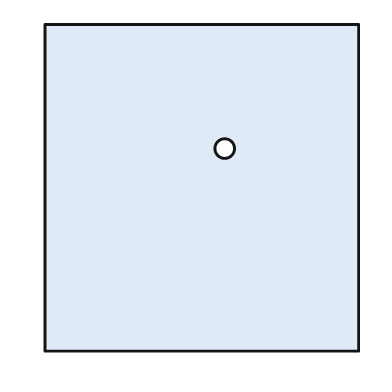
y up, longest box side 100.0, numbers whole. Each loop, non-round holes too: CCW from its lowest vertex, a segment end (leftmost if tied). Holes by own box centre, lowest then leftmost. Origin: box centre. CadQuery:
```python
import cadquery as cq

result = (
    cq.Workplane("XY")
    .moveTo(-48.0, -50.0)
    .lineTo(48.0, -50.0)
    .lineTo(48.0, 50.0)
    .lineTo(-48.0, 50.0)
    .close()
    .moveTo(7.0, 12.0)
    .circle(3.0)
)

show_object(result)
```